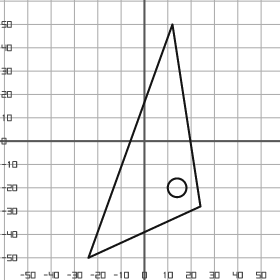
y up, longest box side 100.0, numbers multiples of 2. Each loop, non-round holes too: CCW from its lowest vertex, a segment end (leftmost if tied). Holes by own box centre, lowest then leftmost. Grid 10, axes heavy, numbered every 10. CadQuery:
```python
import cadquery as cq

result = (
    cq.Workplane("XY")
    .moveTo(-24.0, -50.0)
    .lineTo(24.0, -28.0)
    .lineTo(12.0, 50.0)
    .close()
    .moveTo(14.0, -20.0)
    .circle(4.0)
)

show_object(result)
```